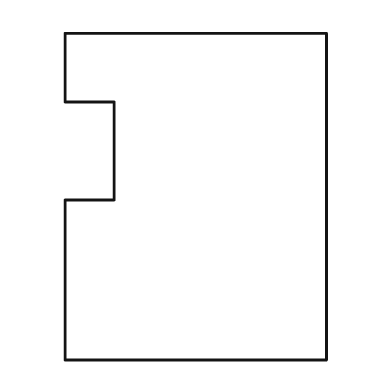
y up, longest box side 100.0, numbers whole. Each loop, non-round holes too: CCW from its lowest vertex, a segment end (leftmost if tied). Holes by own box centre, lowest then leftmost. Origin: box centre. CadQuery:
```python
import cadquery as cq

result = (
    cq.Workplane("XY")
    .moveTo(-40.0, -50.0)
    .lineTo(40.0, -50.0)
    .lineTo(40.0, 50.0)
    .lineTo(-40.0, 50.0)
    .lineTo(-40.0, 29.0)
    .lineTo(-25.0, 29.0)
    .lineTo(-25.0, -1.0)
    .lineTo(-40.0, -1.0)
    .close()
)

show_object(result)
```